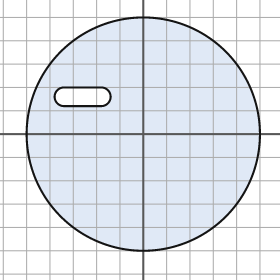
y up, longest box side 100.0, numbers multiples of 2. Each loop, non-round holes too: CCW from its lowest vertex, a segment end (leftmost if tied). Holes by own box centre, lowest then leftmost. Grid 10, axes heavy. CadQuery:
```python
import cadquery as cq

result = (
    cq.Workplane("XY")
    .moveTo(0.0, 0.0)
    .circle(50.0)
    .moveTo(-34.0, 12.0)
    .lineTo(-18.0, 12.0)
    .threePointArc((-14.0, 16.0), (-18.0, 20.0))
    .lineTo(-34.0, 20.0)
    .threePointArc((-38.0, 16.0), (-34.0, 12.0))
    .close()
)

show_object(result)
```